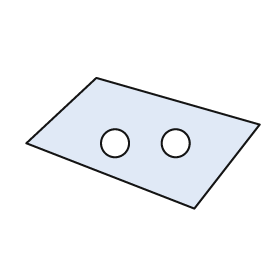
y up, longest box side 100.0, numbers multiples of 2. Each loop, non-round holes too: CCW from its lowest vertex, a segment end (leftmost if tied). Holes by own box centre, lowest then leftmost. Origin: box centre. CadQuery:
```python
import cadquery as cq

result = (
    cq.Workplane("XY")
    .moveTo(22.0, -28.0)
    .lineTo(50.0, 8.0)
    .lineTo(-20.0, 28.0)
    .lineTo(-50.0, 0.0)
    .close()
    .moveTo(-12.0, 0.0)
    .circle(6.0)
    .moveTo(14.0, 0.0)
    .circle(6.0)
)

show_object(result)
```